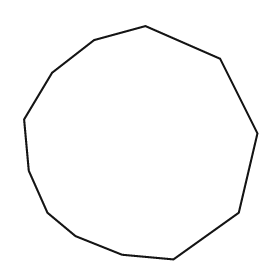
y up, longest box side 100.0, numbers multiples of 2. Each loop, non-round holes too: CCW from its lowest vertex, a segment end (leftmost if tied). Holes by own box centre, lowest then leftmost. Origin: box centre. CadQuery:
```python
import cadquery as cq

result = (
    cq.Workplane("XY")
    .moveTo(14.0, -50.0)
    .lineTo(42.0, -30.0)
    .lineTo(50.0, 4.0)
    .lineTo(34.0, 36.0)
    .lineTo(2.0, 50.0)
    .lineTo(-20.0, 44.0)
    .lineTo(-38.0, 30.0)
    .lineTo(-50.0, 10.0)
    .lineTo(-48.0, -12.0)
    .lineTo(-40.0, -30.0)
    .lineTo(-28.0, -40.0)
    .lineTo(-8.0, -48.0)
    .close()
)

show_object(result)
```